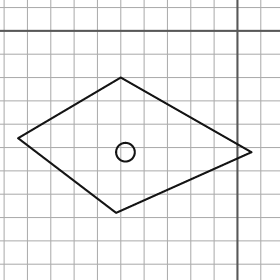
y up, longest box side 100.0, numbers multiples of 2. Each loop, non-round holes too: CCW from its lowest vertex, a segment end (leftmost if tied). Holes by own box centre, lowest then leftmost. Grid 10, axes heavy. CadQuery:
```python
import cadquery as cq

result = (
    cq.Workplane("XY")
    .moveTo(-52.0, -78.0)
    .lineTo(6.0, -52.0)
    .lineTo(-50.0, -20.0)
    .lineTo(-94.0, -46.0)
    .close()
    .moveTo(-48.0, -52.0)
    .circle(4.0)
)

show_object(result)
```